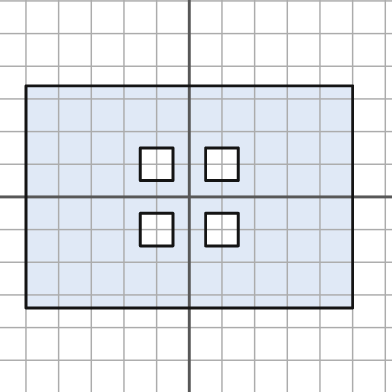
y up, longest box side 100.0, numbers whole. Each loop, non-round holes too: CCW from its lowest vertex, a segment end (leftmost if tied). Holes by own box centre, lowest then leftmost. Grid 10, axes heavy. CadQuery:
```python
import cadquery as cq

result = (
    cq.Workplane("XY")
    .moveTo(-50.0, -34.0)
    .lineTo(50.0, -34.0)
    .lineTo(50.0, 34.0)
    .lineTo(-50.0, 34.0)
    .close()
    .moveTo(-15.0, -15.0)
    .lineTo(-5.0, -15.0)
    .lineTo(-5.0, -5.0)
    .lineTo(-15.0, -5.0)
    .close()
    .moveTo(5.0, -15.0)
    .lineTo(15.0, -15.0)
    .lineTo(15.0, -5.0)
    .lineTo(5.0, -5.0)
    .close()
    .moveTo(-15.0, 5.0)
    .lineTo(-5.0, 5.0)
    .lineTo(-5.0, 15.0)
    .lineTo(-15.0, 15.0)
    .close()
    .moveTo(5.0, 5.0)
    .lineTo(15.0, 5.0)
    .lineTo(15.0, 15.0)
    .lineTo(5.0, 15.0)
    .close()
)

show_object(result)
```